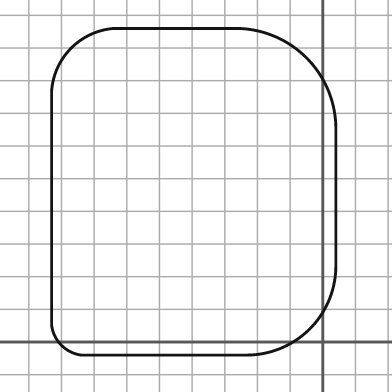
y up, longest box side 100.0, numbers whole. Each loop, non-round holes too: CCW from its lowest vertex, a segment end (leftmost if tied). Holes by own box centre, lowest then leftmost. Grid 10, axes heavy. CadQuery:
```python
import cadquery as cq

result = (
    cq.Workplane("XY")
    .moveTo(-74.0, -4.0)
    .lineTo(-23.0, -4.0)
    .threePointArc((-4.0, 4.0), (4.0, 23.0))
    .lineTo(4.0, 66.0)
    .threePointArc((-5.0, 87.0), (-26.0, 96.0))
    .lineTo(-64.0, 96.0)
    .threePointArc((-77.0, 90.0), (-83.0, 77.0))
    .lineTo(-83.0, 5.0)
    .threePointArc((-80.0, -1.0), (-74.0, -4.0))
    .close()
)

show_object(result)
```